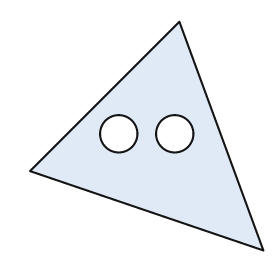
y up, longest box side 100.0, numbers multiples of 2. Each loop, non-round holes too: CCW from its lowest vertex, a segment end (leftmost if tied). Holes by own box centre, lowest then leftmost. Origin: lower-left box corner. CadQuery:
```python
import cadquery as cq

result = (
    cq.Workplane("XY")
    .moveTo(100.0, 0.0)
    .lineTo(64.0, 98.0)
    .lineTo(0.0, 34.0)
    .close()
    .moveTo(38.0, 50.0)
    .circle(8.0)
    .moveTo(62.0, 50.0)
    .circle(8.0)
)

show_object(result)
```